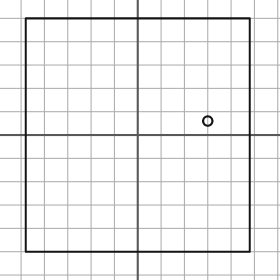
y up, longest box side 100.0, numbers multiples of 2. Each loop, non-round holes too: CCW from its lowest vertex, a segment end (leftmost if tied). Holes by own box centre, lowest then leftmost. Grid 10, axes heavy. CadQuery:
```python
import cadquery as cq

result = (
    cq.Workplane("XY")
    .moveTo(-48.0, -50.0)
    .lineTo(48.0, -50.0)
    .lineTo(48.0, 50.0)
    .lineTo(-48.0, 50.0)
    .close()
    .moveTo(30.0, 6.0)
    .circle(2.0)
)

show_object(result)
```